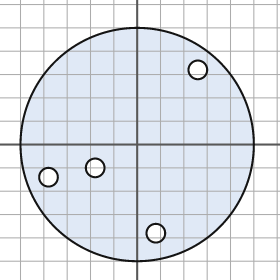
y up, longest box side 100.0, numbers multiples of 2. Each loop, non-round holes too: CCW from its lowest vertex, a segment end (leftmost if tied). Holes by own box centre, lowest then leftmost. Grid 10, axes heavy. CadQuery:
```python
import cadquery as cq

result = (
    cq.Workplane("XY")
    .moveTo(0.0, 0.0)
    .circle(50.0)
    .moveTo(8.0, -38.0)
    .circle(4.0)
    .moveTo(-38.0, -14.0)
    .circle(4.0)
    .moveTo(-18.0, -10.0)
    .circle(4.0)
    .moveTo(26.0, 32.0)
    .circle(4.0)
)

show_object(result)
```